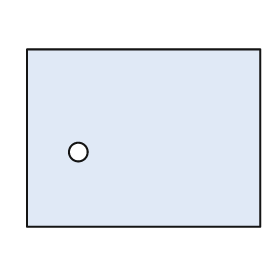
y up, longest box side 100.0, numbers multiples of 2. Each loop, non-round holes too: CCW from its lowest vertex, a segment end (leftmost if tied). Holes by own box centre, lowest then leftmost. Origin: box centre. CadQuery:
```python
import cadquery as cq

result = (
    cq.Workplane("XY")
    .moveTo(-50.0, -38.0)
    .lineTo(50.0, -38.0)
    .lineTo(50.0, 38.0)
    .lineTo(-50.0, 38.0)
    .close()
    .moveTo(-28.0, -6.0)
    .circle(4.0)
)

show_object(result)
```